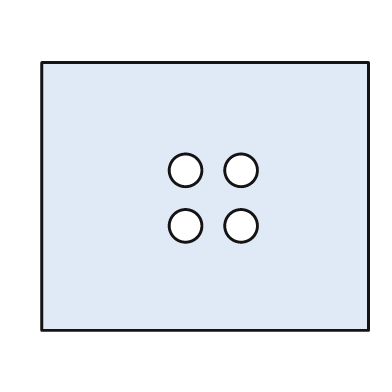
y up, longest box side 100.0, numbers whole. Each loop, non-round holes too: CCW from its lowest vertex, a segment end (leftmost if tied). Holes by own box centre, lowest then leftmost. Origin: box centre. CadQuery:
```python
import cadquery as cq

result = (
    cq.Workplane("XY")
    .moveTo(-50.0, -41.0)
    .lineTo(50.0, -41.0)
    .lineTo(50.0, 41.0)
    .lineTo(-50.0, 41.0)
    .close()
    .moveTo(-6.0, -9.0)
    .circle(5.0)
    .moveTo(11.0, -9.0)
    .circle(5.0)
    .moveTo(-6.0, 8.0)
    .circle(5.0)
    .moveTo(11.0, 8.0)
    .circle(5.0)
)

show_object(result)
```